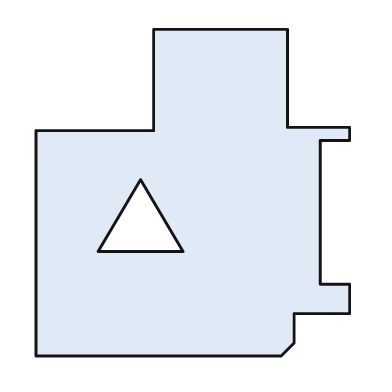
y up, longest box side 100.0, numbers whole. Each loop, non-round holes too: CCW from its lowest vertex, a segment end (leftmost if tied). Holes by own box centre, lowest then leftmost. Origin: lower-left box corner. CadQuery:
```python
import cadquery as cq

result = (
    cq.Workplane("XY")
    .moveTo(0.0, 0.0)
    .lineTo(75.0, 0.0)
    .lineTo(79.0, 4.0)
    .lineTo(79.0, 13.0)
    .lineTo(96.0, 13.0)
    .lineTo(96.0, 22.0)
    .lineTo(87.0, 22.0)
    .lineTo(87.0, 66.0)
    .lineTo(96.0, 66.0)
    .lineTo(96.0, 70.0)
    .lineTo(77.0, 70.0)
    .lineTo(77.0, 100.0)
    .lineTo(36.0, 100.0)
    .lineTo(36.0, 69.0)
    .lineTo(0.0, 69.0)
    .close()
    .moveTo(19.0, 32.0)
    .lineTo(45.0, 32.0)
    .lineTo(32.0, 54.0)
    .close()
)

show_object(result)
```